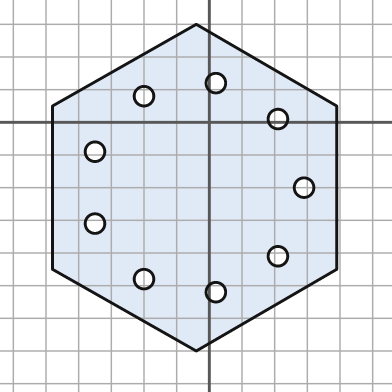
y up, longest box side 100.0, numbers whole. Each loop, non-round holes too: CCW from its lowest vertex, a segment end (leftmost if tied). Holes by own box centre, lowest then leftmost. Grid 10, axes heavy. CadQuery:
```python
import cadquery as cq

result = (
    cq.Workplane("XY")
    .moveTo(-4.0, -70.0)
    .lineTo(39.0, -45.0)
    .lineTo(39.0, 5.0)
    .lineTo(-4.0, 30.0)
    .lineTo(-48.0, 5.0)
    .lineTo(-48.0, -45.0)
    .close()
    .moveTo(2.0, -52.0)
    .circle(3.0)
    .moveTo(-20.0, -48.0)
    .circle(3.0)
    .moveTo(21.0, -41.0)
    .circle(3.0)
    .moveTo(-35.0, -31.0)
    .circle(3.0)
    .moveTo(29.0, -20.0)
    .circle(3.0)
    .moveTo(-35.0, -9.0)
    .circle(3.0)
    .moveTo(21.0, 1.0)
    .circle(3.0)
    .moveTo(-20.0, 8.0)
    .circle(3.0)
    .moveTo(2.0, 12.0)
    .circle(3.0)
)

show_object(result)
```